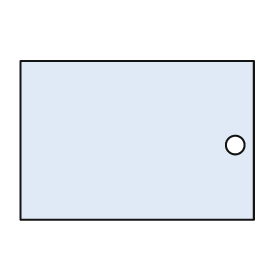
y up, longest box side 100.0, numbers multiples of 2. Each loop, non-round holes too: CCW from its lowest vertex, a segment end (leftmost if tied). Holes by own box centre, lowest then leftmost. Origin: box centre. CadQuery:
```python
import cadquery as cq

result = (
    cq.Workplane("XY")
    .moveTo(-50.0, -34.0)
    .lineTo(50.0, -34.0)
    .lineTo(50.0, 34.0)
    .lineTo(-50.0, 34.0)
    .close()
    .moveTo(42.0, -2.0)
    .circle(4.0)
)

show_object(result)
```